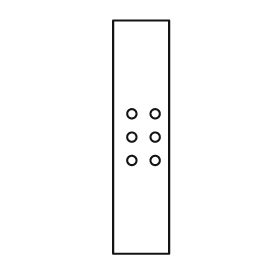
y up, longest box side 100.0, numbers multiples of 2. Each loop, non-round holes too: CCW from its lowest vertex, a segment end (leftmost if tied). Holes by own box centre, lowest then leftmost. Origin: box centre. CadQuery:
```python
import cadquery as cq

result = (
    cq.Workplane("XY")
    .moveTo(-12.0, -50.0)
    .lineTo(12.0, -50.0)
    .lineTo(12.0, 50.0)
    .lineTo(-12.0, 50.0)
    .close()
    .moveTo(-4.0, -10.0)
    .circle(2.0)
    .moveTo(6.0, -10.0)
    .circle(2.0)
    .moveTo(-4.0, 0.0)
    .circle(2.0)
    .moveTo(6.0, 0.0)
    .circle(2.0)
    .moveTo(-4.0, 10.0)
    .circle(2.0)
    .moveTo(6.0, 10.0)
    .circle(2.0)
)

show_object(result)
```